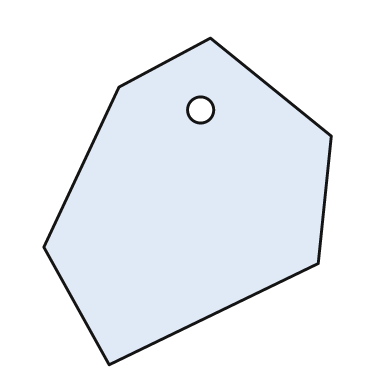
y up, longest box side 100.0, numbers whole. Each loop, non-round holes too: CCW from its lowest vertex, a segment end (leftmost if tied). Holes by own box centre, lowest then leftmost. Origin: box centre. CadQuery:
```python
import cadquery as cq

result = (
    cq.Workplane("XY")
    .moveTo(-24.0, -50.0)
    .lineTo(40.0, -19.0)
    .lineTo(44.0, 20.0)
    .lineTo(7.0, 50.0)
    .lineTo(-21.0, 35.0)
    .lineTo(-44.0, -14.0)
    .close()
    .moveTo(4.0, 28.0)
    .circle(4.0)
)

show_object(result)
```